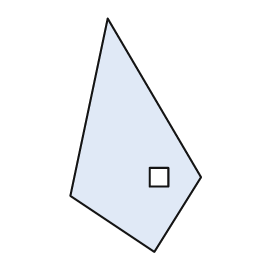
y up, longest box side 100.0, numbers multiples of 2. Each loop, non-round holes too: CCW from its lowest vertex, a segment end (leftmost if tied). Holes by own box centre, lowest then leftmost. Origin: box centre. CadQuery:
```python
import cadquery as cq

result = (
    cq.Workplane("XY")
    .moveTo(8.0, -50.0)
    .lineTo(28.0, -18.0)
    .lineTo(-12.0, 50.0)
    .lineTo(-28.0, -26.0)
    .close()
    .moveTo(6.0, -22.0)
    .lineTo(14.0, -22.0)
    .lineTo(14.0, -14.0)
    .lineTo(6.0, -14.0)
    .close()
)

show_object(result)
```